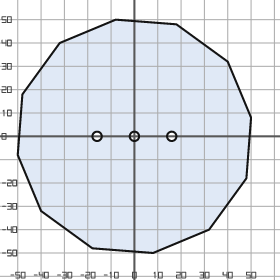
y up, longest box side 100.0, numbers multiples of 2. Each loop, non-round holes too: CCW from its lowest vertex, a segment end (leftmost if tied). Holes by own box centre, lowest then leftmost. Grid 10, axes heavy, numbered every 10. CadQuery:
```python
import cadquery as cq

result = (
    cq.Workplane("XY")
    .moveTo(8.0, -50.0)
    .lineTo(32.0, -40.0)
    .lineTo(48.0, -18.0)
    .lineTo(50.0, 8.0)
    .lineTo(40.0, 32.0)
    .lineTo(18.0, 48.0)
    .lineTo(-8.0, 50.0)
    .lineTo(-32.0, 40.0)
    .lineTo(-48.0, 18.0)
    .lineTo(-50.0, -8.0)
    .lineTo(-40.0, -32.0)
    .lineTo(-18.0, -48.0)
    .close()
    .moveTo(-16.0, 0.0)
    .circle(2.0)
    .moveTo(0.0, 0.0)
    .circle(2.0)
    .moveTo(16.0, 0.0)
    .circle(2.0)
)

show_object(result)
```